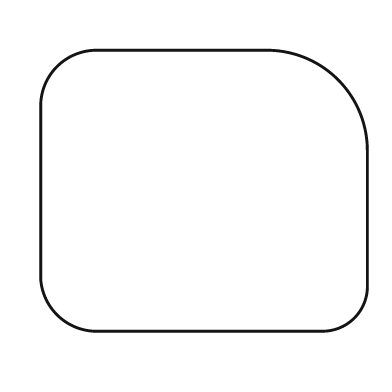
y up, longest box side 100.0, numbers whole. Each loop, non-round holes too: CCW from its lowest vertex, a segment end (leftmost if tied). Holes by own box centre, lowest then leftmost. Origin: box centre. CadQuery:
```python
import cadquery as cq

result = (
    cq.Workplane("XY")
    .moveTo(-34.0, -43.0)
    .lineTo(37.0, -43.0)
    .threePointArc((46.0, -39.0), (50.0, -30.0))
    .lineTo(50.0, 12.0)
    .threePointArc((41.0, 34.0), (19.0, 43.0))
    .lineTo(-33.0, 43.0)
    .threePointArc((-45.0, 38.0), (-50.0, 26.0))
    .lineTo(-50.0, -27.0)
    .threePointArc((-45.0, -38.0), (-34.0, -43.0))
    .close()
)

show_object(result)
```